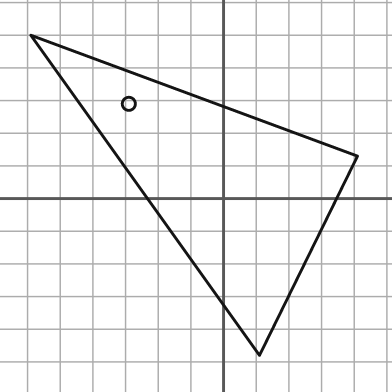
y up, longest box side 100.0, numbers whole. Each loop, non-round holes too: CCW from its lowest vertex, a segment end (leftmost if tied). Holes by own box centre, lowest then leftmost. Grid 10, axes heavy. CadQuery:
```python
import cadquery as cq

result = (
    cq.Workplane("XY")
    .moveTo(11.0, -48.0)
    .lineTo(41.0, 13.0)
    .lineTo(-59.0, 50.0)
    .close()
    .moveTo(-29.0, 29.0)
    .circle(2.0)
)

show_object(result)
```